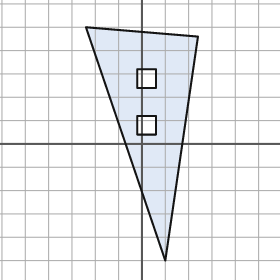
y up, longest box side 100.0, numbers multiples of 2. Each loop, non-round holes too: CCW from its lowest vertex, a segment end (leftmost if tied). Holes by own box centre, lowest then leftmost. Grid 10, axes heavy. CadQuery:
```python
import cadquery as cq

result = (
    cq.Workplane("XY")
    .moveTo(10.0, -50.0)
    .lineTo(24.0, 46.0)
    .lineTo(-24.0, 50.0)
    .close()
    .moveTo(-2.0, 4.0)
    .lineTo(6.0, 4.0)
    .lineTo(6.0, 12.0)
    .lineTo(-2.0, 12.0)
    .close()
    .moveTo(-2.0, 24.0)
    .lineTo(6.0, 24.0)
    .lineTo(6.0, 32.0)
    .lineTo(-2.0, 32.0)
    .close()
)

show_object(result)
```